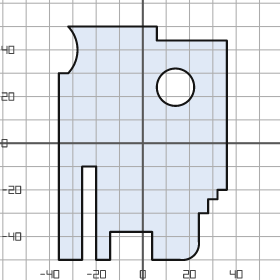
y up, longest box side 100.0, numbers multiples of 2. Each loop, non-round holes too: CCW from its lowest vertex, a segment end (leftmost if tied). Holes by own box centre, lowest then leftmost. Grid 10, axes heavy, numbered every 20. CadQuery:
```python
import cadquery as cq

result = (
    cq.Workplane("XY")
    .moveTo(-36.0, -50.0)
    .lineTo(-26.0, -50.0)
    .lineTo(-26.0, -10.0)
    .lineTo(-20.0, -10.0)
    .lineTo(-20.0, -50.0)
    .lineTo(-14.0, -50.0)
    .lineTo(-14.0, -38.0)
    .lineTo(4.0, -38.0)
    .lineTo(4.0, -50.0)
    .lineTo(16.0, -50.0)
    .threePointArc((22.0, -48.0), (24.0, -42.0))
    .lineTo(24.0, -30.0)
    .lineTo(28.0, -30.0)
    .lineTo(28.0, -24.0)
    .lineTo(32.0, -24.0)
    .lineTo(32.0, -20.0)
    .lineTo(36.0, -20.0)
    .lineTo(36.0, 44.0)
    .lineTo(6.0, 44.0)
    .lineTo(6.0, 50.0)
    .lineTo(-32.0, 50.0)
    .threePointArc((-28.0, 40.0), (-32.0, 30.0))
    .lineTo(-36.0, 30.0)
    .close()
    .moveTo(14.0, 24.0)
    .circle(8.0)
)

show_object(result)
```